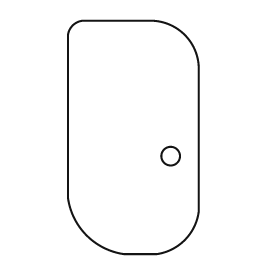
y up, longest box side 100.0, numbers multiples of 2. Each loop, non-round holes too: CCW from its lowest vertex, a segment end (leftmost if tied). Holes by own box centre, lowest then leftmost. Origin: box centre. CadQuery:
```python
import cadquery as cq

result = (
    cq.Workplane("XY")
    .moveTo(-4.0, -50.0)
    .lineTo(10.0, -50.0)
    .threePointArc((22.0, -44.0), (28.0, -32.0))
    .lineTo(28.0, 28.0)
    .threePointArc((22.0, 44.0), (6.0, 50.0))
    .lineTo(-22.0, 50.0)
    .threePointArc((-26.0, 48.0), (-28.0, 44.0))
    .lineTo(-28.0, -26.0)
    .threePointArc((-20.0, -42.0), (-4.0, -50.0))
    .close()
    .moveTo(16.0, -8.0)
    .circle(4.0)
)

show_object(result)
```